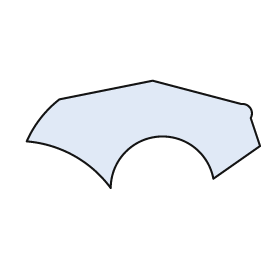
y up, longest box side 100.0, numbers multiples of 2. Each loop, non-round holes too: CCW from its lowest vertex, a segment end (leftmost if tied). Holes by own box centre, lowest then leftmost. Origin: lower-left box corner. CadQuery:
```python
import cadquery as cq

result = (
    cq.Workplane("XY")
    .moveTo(36.0, 0.0)
    .threePointArc((56.0, 22.0), (80.0, 4.0))
    .lineTo(100.0, 18.0)
    .lineTo(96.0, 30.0)
    .threePointArc((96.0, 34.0), (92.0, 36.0))
    .lineTo(54.0, 46.0)
    .lineTo(14.0, 38.0)
    .threePointArc((6.0, 30.0), (0.0, 20.0))
    .threePointArc((20.0, 14.0), (36.0, 0.0))
    .close()
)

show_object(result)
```